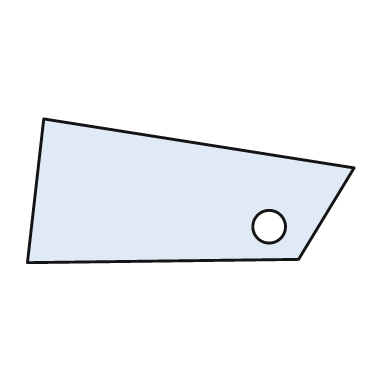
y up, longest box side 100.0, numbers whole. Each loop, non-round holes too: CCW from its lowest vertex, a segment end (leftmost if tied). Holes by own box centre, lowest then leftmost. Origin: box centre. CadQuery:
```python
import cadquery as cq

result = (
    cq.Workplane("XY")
    .moveTo(-50.0, -22.0)
    .lineTo(33.0, -21.0)
    .lineTo(50.0, 7.0)
    .lineTo(-45.0, 22.0)
    .close()
    .moveTo(24.0, -11.0)
    .circle(5.0)
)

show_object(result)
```